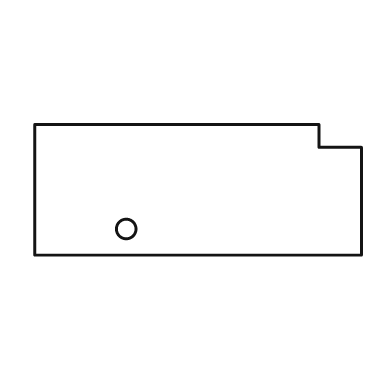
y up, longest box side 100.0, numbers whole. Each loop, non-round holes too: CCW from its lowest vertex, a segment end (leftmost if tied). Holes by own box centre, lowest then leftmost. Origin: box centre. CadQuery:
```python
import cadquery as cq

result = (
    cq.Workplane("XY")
    .moveTo(-50.0, -20.0)
    .lineTo(50.0, -20.0)
    .lineTo(50.0, 13.0)
    .lineTo(37.0, 13.0)
    .lineTo(37.0, 20.0)
    .lineTo(-50.0, 20.0)
    .close()
    .moveTo(-22.0, -12.0)
    .circle(3.0)
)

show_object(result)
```